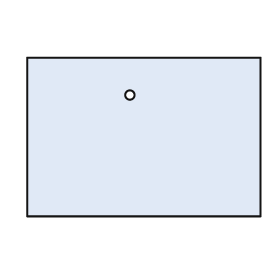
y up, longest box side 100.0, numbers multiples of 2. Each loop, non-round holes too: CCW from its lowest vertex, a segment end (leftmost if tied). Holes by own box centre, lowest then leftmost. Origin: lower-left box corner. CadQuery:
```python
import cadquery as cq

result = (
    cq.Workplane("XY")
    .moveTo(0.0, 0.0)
    .lineTo(100.0, 0.0)
    .lineTo(100.0, 68.0)
    .lineTo(0.0, 68.0)
    .close()
    .moveTo(44.0, 52.0)
    .circle(2.0)
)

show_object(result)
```